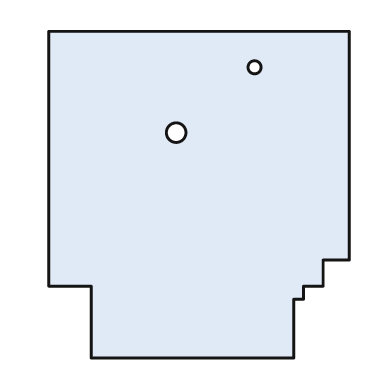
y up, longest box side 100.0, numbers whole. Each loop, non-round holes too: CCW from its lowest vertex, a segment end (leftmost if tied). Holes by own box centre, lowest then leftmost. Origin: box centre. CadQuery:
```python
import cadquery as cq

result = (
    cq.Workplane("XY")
    .moveTo(-33.0, -50.0)
    .lineTo(29.0, -50.0)
    .lineTo(29.0, -32.0)
    .lineTo(32.0, -32.0)
    .lineTo(32.0, -28.0)
    .lineTo(38.0, -28.0)
    .lineTo(38.0, -20.0)
    .lineTo(46.0, -20.0)
    .lineTo(46.0, 50.0)
    .lineTo(-46.0, 50.0)
    .lineTo(-46.0, -28.0)
    .lineTo(-33.0, -28.0)
    .close()
    .moveTo(-7.0, 19.0)
    .circle(3.0)
    .moveTo(17.0, 39.0)
    .circle(2.0)
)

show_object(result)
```